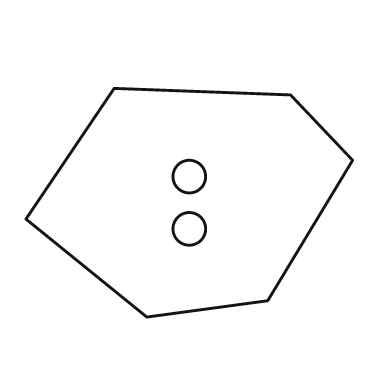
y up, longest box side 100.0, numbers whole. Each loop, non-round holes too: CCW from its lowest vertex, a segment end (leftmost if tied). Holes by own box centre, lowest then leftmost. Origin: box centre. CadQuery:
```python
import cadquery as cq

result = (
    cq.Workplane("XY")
    .moveTo(-13.0, -35.0)
    .lineTo(24.0, -30.0)
    .lineTo(50.0, 13.0)
    .lineTo(31.0, 33.0)
    .lineTo(-23.0, 35.0)
    .lineTo(-50.0, -5.0)
    .close()
    .moveTo(0.0, -8.0)
    .circle(5.0)
    .moveTo(0.0, 8.0)
    .circle(5.0)
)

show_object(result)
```